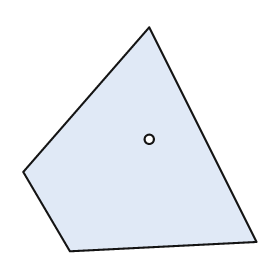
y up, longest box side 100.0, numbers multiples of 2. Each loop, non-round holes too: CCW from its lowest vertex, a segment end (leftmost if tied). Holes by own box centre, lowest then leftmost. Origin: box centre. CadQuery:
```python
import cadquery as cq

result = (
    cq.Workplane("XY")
    .moveTo(-30.0, -48.0)
    .lineTo(50.0, -44.0)
    .lineTo(4.0, 48.0)
    .lineTo(-50.0, -14.0)
    .close()
    .moveTo(4.0, 0.0)
    .circle(2.0)
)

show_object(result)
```